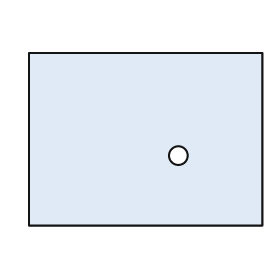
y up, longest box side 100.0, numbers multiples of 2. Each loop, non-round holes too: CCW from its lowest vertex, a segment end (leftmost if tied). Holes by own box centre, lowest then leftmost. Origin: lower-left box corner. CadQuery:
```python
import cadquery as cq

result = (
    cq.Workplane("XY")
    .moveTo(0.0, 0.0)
    .lineTo(100.0, 0.0)
    .lineTo(100.0, 74.0)
    .lineTo(0.0, 74.0)
    .close()
    .moveTo(64.0, 30.0)
    .circle(4.0)
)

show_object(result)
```